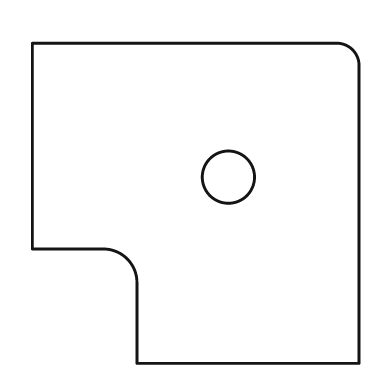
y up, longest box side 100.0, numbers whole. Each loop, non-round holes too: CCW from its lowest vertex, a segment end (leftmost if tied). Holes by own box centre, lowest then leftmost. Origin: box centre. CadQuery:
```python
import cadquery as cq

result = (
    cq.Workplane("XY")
    .moveTo(-18.0, -49.0)
    .lineTo(50.0, -49.0)
    .lineTo(50.0, 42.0)
    .threePointArc((48.0, 47.0), (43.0, 49.0))
    .lineTo(-50.0, 49.0)
    .lineTo(-50.0, -14.0)
    .lineTo(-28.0, -14.0)
    .threePointArc((-21.0, -17.0), (-18.0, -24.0))
    .close()
    .moveTo(10.0, 8.0)
    .circle(8.0)
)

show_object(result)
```